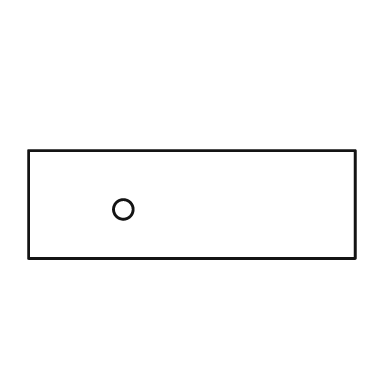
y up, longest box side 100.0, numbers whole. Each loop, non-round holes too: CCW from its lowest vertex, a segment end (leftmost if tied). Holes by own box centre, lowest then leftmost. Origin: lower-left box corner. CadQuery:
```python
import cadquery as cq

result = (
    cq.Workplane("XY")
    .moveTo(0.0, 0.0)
    .lineTo(100.0, 0.0)
    .lineTo(100.0, 33.0)
    .lineTo(0.0, 33.0)
    .close()
    .moveTo(29.0, 15.0)
    .circle(3.0)
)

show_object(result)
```